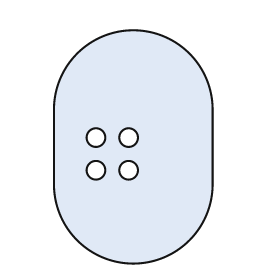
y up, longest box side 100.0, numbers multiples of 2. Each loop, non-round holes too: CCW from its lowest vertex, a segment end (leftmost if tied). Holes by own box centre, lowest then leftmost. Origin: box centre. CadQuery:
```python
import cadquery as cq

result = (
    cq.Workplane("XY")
    .moveTo(-34.0, -16.0)
    .threePointArc((0.0, -50.0), (34.0, -16.0))
    .lineTo(34.0, 16.0)
    .threePointArc((0.0, 50.0), (-34.0, 16.0))
    .close()
    .moveTo(-16.0, -10.0)
    .circle(4.0)
    .moveTo(-2.0, -10.0)
    .circle(4.0)
    .moveTo(-16.0, 4.0)
    .circle(4.0)
    .moveTo(-2.0, 4.0)
    .circle(4.0)
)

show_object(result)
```